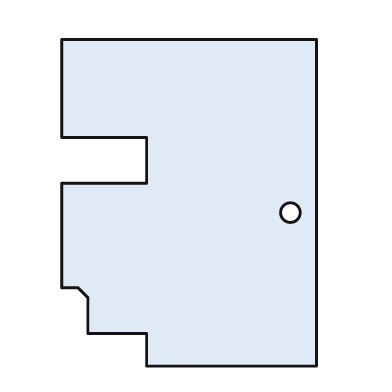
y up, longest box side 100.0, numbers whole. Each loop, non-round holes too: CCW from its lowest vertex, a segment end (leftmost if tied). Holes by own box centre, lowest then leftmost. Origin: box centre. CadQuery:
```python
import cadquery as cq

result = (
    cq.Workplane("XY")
    .moveTo(-13.0, -50.0)
    .lineTo(39.0, -50.0)
    .lineTo(39.0, 50.0)
    .lineTo(-39.0, 50.0)
    .lineTo(-39.0, 20.0)
    .lineTo(-13.0, 20.0)
    .lineTo(-13.0, 6.0)
    .lineTo(-39.0, 6.0)
    .lineTo(-39.0, -26.0)
    .lineTo(-34.0, -26.0)
    .lineTo(-31.0, -29.0)
    .lineTo(-31.0, -40.0)
    .lineTo(-13.0, -40.0)
    .close()
    .moveTo(31.0, -3.0)
    .circle(3.0)
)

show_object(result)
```